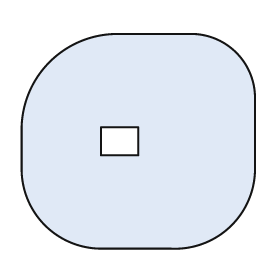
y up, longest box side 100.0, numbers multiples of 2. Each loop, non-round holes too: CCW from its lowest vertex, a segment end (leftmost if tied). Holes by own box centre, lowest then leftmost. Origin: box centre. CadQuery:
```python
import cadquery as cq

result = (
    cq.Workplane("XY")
    .moveTo(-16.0, -46.0)
    .lineTo(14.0, -46.0)
    .threePointArc((40.0, -36.0), (50.0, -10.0))
    .lineTo(50.0, 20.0)
    .threePointArc((42.0, 38.0), (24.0, 46.0))
    .lineTo(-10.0, 46.0)
    .threePointArc((-38.0, 34.0), (-50.0, 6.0))
    .lineTo(-50.0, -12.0)
    .threePointArc((-40.0, -36.0), (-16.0, -46.0))
    .close()
    .moveTo(-16.0, -6.0)
    .lineTo(0.0, -6.0)
    .lineTo(0.0, 6.0)
    .lineTo(-16.0, 6.0)
    .close()
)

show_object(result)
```